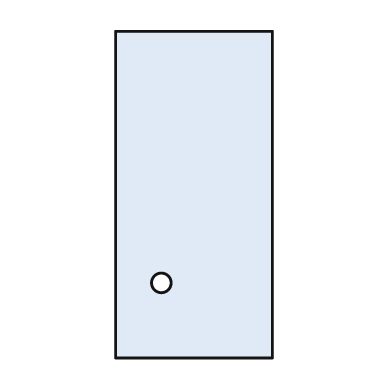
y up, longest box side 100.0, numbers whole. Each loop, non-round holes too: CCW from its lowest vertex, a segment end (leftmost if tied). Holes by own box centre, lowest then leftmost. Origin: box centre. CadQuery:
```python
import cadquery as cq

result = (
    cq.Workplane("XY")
    .moveTo(-24.0, -50.0)
    .lineTo(24.0, -50.0)
    .lineTo(24.0, 50.0)
    .lineTo(-24.0, 50.0)
    .close()
    .moveTo(-10.0, -27.0)
    .circle(3.0)
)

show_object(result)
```